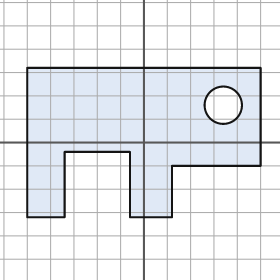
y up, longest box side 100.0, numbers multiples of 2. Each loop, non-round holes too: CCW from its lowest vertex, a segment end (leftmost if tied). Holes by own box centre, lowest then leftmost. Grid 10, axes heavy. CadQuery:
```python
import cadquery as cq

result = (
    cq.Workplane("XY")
    .moveTo(-50.0, -32.0)
    .lineTo(-34.0, -32.0)
    .lineTo(-34.0, -4.0)
    .lineTo(-6.0, -4.0)
    .lineTo(-6.0, -32.0)
    .lineTo(12.0, -32.0)
    .lineTo(12.0, -10.0)
    .lineTo(50.0, -10.0)
    .lineTo(50.0, 32.0)
    .lineTo(-50.0, 32.0)
    .close()
    .moveTo(34.0, 16.0)
    .circle(8.0)
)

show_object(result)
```